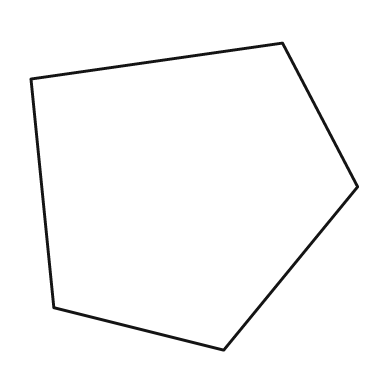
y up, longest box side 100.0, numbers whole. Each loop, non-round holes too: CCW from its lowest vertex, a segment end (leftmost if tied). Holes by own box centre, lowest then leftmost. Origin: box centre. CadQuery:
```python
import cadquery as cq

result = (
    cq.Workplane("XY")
    .moveTo(9.0, -47.0)
    .lineTo(50.0, 3.0)
    .lineTo(27.0, 47.0)
    .lineTo(-50.0, 36.0)
    .lineTo(-43.0, -34.0)
    .close()
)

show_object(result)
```